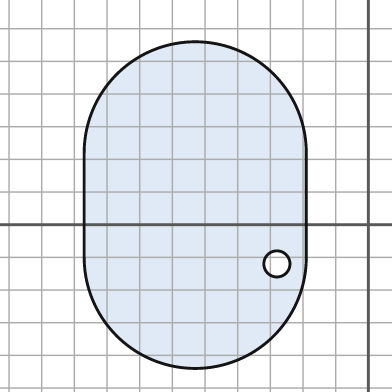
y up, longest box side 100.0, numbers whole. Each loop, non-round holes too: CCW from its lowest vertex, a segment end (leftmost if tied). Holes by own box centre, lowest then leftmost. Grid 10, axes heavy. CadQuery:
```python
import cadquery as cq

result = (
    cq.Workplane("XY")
    .moveTo(-87.0, -10.0)
    .threePointArc((-53.0, -44.0), (-19.0, -10.0))
    .lineTo(-19.0, 22.0)
    .threePointArc((-53.0, 56.0), (-87.0, 22.0))
    .close()
    .moveTo(-28.0, -12.0)
    .circle(4.0)
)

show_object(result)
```